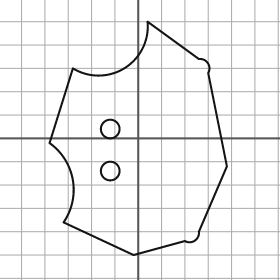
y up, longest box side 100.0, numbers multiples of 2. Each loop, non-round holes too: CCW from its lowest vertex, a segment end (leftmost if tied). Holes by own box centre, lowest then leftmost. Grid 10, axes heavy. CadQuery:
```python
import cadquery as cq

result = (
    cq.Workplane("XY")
    .moveTo(-2.0, -50.0)
    .lineTo(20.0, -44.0)
    .threePointArc((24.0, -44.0), (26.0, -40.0))
    .lineTo(38.0, -12.0)
    .lineTo(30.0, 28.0)
    .threePointArc((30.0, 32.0), (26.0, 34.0))
    .lineTo(4.0, 50.0)
    .threePointArc((-6.0, 30.0), (-28.0, 30.0))
    .lineTo(-38.0, -2.0)
    .threePointArc((-28.0, -18.0), (-32.0, -36.0))
    .close()
    .moveTo(-12.0, -14.0)
    .circle(4.0)
    .moveTo(-12.0, 4.0)
    .circle(4.0)
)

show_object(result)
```